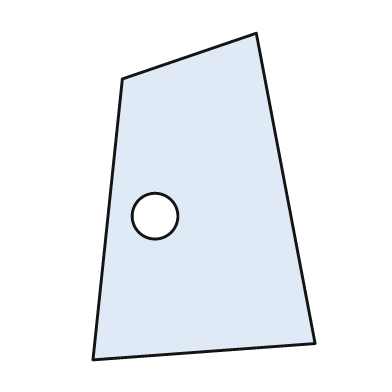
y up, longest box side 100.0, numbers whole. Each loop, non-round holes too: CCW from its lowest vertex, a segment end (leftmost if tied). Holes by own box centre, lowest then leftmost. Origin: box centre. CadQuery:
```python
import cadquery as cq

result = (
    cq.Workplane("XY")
    .moveTo(-34.0, -50.0)
    .lineTo(34.0, -45.0)
    .lineTo(16.0, 50.0)
    .lineTo(-25.0, 36.0)
    .close()
    .moveTo(-15.0, -6.0)
    .circle(7.0)
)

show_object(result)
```